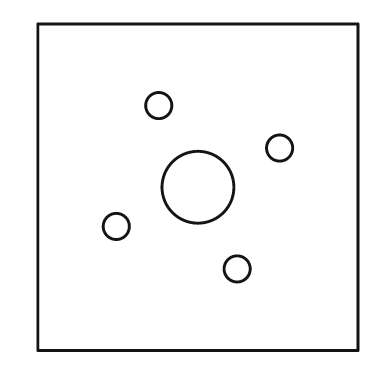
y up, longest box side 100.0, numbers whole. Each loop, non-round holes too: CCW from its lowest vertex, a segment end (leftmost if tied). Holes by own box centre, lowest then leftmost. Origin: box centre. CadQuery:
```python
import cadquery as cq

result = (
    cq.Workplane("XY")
    .moveTo(-49.0, -50.0)
    .lineTo(49.0, -50.0)
    .lineTo(49.0, 50.0)
    .lineTo(-49.0, 50.0)
    .close()
    .moveTo(12.0, -25.0)
    .circle(4.0)
    .moveTo(-25.0, -12.0)
    .circle(4.0)
    .moveTo(0.0, 0.0)
    .circle(11.0)
    .moveTo(25.0, 12.0)
    .circle(4.0)
    .moveTo(-12.0, 25.0)
    .circle(4.0)
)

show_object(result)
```